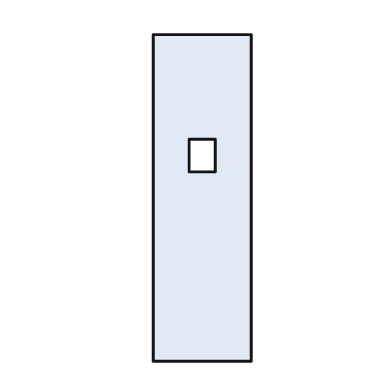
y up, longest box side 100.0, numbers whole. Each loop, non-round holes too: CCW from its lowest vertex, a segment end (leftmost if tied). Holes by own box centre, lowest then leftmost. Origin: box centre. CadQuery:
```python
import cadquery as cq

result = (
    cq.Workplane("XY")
    .moveTo(-15.0, -50.0)
    .lineTo(15.0, -50.0)
    .lineTo(15.0, 50.0)
    .lineTo(-15.0, 50.0)
    .close()
    .moveTo(-4.0, 8.0)
    .lineTo(4.0, 8.0)
    .lineTo(4.0, 18.0)
    .lineTo(-4.0, 18.0)
    .close()
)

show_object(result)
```